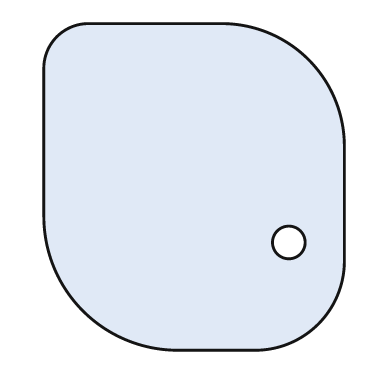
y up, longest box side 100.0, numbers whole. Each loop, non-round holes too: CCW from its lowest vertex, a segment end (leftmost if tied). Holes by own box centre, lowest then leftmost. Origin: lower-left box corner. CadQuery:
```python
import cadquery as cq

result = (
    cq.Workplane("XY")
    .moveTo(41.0, 0.0)
    .lineTo(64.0, 0.0)
    .threePointArc((84.0, 8.0), (92.0, 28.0))
    .lineTo(92.0, 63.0)
    .threePointArc((81.0, 89.0), (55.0, 100.0))
    .lineTo(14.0, 100.0)
    .threePointArc((4.0, 96.0), (0.0, 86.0))
    .lineTo(0.0, 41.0)
    .threePointArc((12.0, 12.0), (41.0, 0.0))
    .close()
    .moveTo(75.0, 33.0)
    .circle(5.0)
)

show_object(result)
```